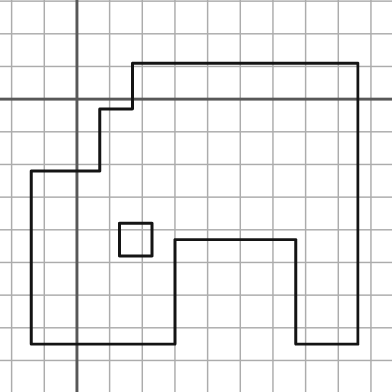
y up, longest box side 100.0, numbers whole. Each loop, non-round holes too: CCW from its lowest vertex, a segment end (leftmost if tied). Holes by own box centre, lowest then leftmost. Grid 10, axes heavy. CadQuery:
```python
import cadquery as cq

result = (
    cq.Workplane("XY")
    .moveTo(-14.0, -75.0)
    .lineTo(30.0, -75.0)
    .lineTo(30.0, -43.0)
    .lineTo(67.0, -43.0)
    .lineTo(67.0, -75.0)
    .lineTo(86.0, -75.0)
    .lineTo(86.0, 11.0)
    .lineTo(17.0, 11.0)
    .lineTo(17.0, -3.0)
    .lineTo(7.0, -3.0)
    .lineTo(7.0, -22.0)
    .lineTo(-14.0, -22.0)
    .close()
    .moveTo(13.0, -48.0)
    .lineTo(23.0, -48.0)
    .lineTo(23.0, -38.0)
    .lineTo(13.0, -38.0)
    .close()
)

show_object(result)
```